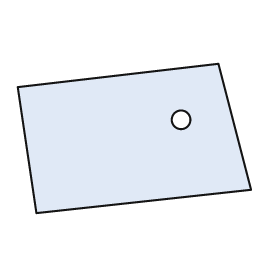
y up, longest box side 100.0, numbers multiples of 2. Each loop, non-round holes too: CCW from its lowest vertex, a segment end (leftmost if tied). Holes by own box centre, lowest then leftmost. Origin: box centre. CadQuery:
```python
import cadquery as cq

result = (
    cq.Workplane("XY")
    .moveTo(-42.0, -32.0)
    .lineTo(50.0, -22.0)
    .lineTo(36.0, 32.0)
    .lineTo(-50.0, 22.0)
    .close()
    .moveTo(20.0, 8.0)
    .circle(4.0)
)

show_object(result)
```